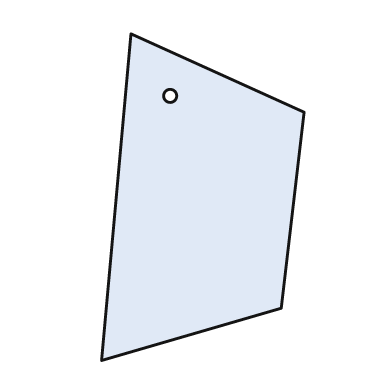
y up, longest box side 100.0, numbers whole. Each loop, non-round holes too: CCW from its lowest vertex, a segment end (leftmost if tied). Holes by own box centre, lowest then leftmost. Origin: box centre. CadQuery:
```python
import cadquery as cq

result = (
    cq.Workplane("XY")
    .moveTo(-31.0, -50.0)
    .lineTo(24.0, -34.0)
    .lineTo(31.0, 26.0)
    .lineTo(-22.0, 50.0)
    .close()
    .moveTo(-10.0, 31.0)
    .circle(2.0)
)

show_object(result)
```